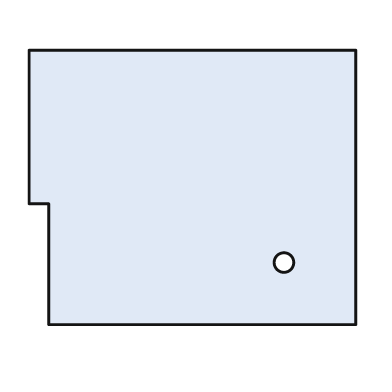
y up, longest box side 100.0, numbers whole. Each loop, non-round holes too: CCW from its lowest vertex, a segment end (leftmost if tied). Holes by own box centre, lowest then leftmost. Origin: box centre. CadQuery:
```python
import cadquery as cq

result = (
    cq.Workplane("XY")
    .moveTo(-44.0, -42.0)
    .lineTo(50.0, -42.0)
    .lineTo(50.0, 42.0)
    .lineTo(-50.0, 42.0)
    .lineTo(-50.0, -5.0)
    .lineTo(-44.0, -5.0)
    .close()
    .moveTo(28.0, -23.0)
    .circle(3.0)
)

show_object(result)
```